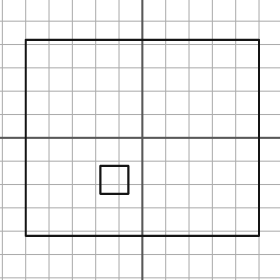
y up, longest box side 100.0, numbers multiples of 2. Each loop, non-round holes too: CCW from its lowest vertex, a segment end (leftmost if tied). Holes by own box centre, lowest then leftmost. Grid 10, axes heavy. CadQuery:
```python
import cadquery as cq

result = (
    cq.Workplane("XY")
    .moveTo(-50.0, -42.0)
    .lineTo(50.0, -42.0)
    .lineTo(50.0, 42.0)
    .lineTo(-50.0, 42.0)
    .close()
    .moveTo(-18.0, -24.0)
    .lineTo(-6.0, -24.0)
    .lineTo(-6.0, -12.0)
    .lineTo(-18.0, -12.0)
    .close()
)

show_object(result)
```